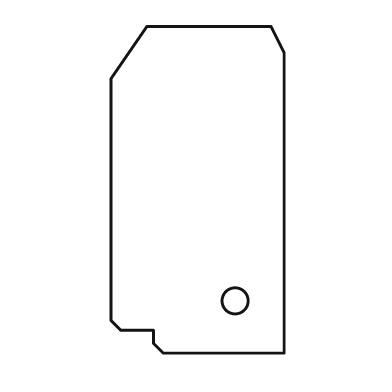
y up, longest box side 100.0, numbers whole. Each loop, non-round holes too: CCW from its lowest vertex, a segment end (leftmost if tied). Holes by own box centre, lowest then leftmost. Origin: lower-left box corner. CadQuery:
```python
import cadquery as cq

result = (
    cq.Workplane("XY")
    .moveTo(16.0, 0.0)
    .lineTo(53.0, 0.0)
    .lineTo(53.0, 92.0)
    .lineTo(49.0, 100.0)
    .lineTo(11.0, 100.0)
    .lineTo(0.0, 84.0)
    .lineTo(0.0, 10.0)
    .lineTo(3.0, 7.0)
    .lineTo(13.0, 7.0)
    .lineTo(13.0, 3.0)
    .close()
    .moveTo(38.0, 16.0)
    .circle(4.0)
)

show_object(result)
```